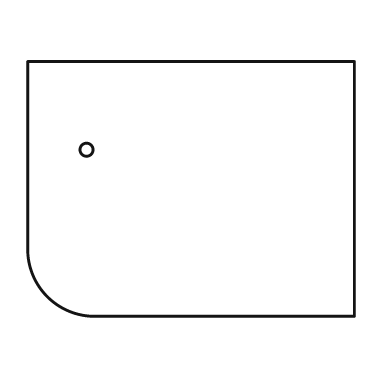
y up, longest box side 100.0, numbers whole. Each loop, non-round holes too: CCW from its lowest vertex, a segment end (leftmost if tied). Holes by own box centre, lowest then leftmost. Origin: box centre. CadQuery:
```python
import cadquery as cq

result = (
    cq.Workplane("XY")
    .moveTo(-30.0, -39.0)
    .lineTo(50.0, -39.0)
    .lineTo(50.0, 39.0)
    .lineTo(-50.0, 39.0)
    .lineTo(-50.0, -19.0)
    .threePointArc((-44.0, -33.0), (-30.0, -39.0))
    .close()
    .moveTo(-32.0, 12.0)
    .circle(2.0)
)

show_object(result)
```